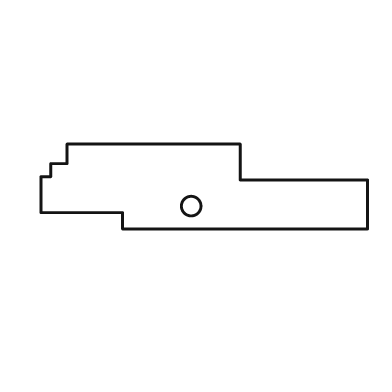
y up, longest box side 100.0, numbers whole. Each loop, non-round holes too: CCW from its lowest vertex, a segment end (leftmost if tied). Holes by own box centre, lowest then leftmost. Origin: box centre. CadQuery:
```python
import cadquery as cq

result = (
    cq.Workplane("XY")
    .moveTo(-25.0, -13.0)
    .lineTo(50.0, -13.0)
    .lineTo(50.0, 2.0)
    .lineTo(11.0, 2.0)
    .lineTo(11.0, 13.0)
    .lineTo(-42.0, 13.0)
    .lineTo(-42.0, 7.0)
    .lineTo(-47.0, 7.0)
    .lineTo(-47.0, 3.0)
    .lineTo(-50.0, 3.0)
    .lineTo(-50.0, -8.0)
    .lineTo(-25.0, -8.0)
    .close()
    .moveTo(-4.0, -6.0)
    .circle(3.0)
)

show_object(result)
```